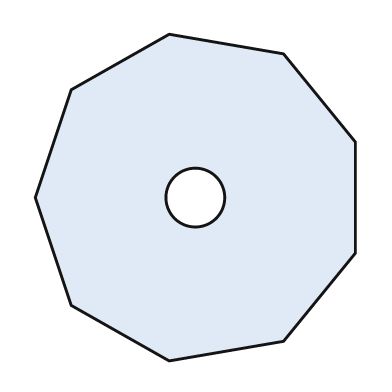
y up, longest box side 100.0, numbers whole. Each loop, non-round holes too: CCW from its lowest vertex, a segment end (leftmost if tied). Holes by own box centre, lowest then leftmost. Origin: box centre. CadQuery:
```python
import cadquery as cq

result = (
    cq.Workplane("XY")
    .moveTo(-8.0, -50.0)
    .lineTo(27.0, -44.0)
    .lineTo(49.0, -17.0)
    .lineTo(49.0, 17.0)
    .lineTo(27.0, 44.0)
    .lineTo(-8.0, 50.0)
    .lineTo(-38.0, 33.0)
    .lineTo(-49.0, 0.0)
    .lineTo(-38.0, -33.0)
    .close()
    .moveTo(0.0, 0.0)
    .circle(9.0)
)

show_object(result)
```